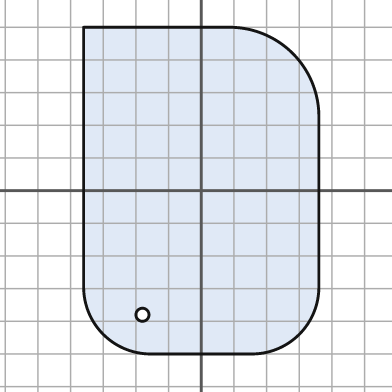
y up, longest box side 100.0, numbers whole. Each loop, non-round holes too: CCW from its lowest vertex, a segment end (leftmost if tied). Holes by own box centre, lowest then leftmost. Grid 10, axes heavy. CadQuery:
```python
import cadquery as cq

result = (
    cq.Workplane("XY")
    .moveTo(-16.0, -50.0)
    .lineTo(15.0, -50.0)
    .threePointArc((30.0, -44.0), (36.0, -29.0))
    .lineTo(36.0, 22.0)
    .threePointArc((28.0, 42.0), (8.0, 50.0))
    .lineTo(-36.0, 50.0)
    .lineTo(-36.0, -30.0)
    .threePointArc((-30.0, -44.0), (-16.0, -50.0))
    .close()
    .moveTo(-18.0, -38.0)
    .circle(2.0)
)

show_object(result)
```